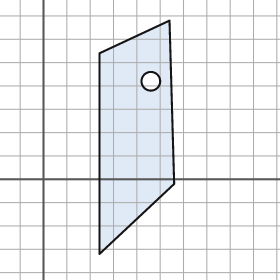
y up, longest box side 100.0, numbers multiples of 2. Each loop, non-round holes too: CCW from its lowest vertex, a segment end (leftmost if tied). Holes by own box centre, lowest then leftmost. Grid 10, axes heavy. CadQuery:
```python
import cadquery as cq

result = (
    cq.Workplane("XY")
    .moveTo(24.0, -32.0)
    .lineTo(56.0, -2.0)
    .lineTo(54.0, 68.0)
    .lineTo(24.0, 54.0)
    .close()
    .moveTo(46.0, 42.0)
    .circle(4.0)
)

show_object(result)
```